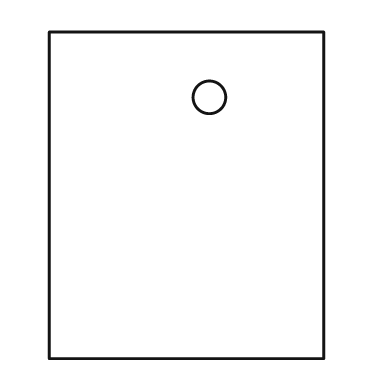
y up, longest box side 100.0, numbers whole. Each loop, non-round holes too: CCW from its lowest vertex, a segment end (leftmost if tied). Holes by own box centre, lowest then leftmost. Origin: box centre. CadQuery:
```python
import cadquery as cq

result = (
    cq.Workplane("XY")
    .moveTo(-42.0, -50.0)
    .lineTo(42.0, -50.0)
    .lineTo(42.0, 50.0)
    .lineTo(-42.0, 50.0)
    .close()
    .moveTo(7.0, 30.0)
    .circle(5.0)
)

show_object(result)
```